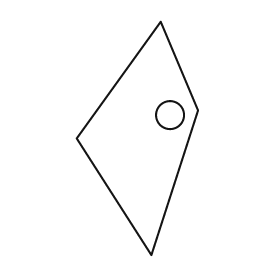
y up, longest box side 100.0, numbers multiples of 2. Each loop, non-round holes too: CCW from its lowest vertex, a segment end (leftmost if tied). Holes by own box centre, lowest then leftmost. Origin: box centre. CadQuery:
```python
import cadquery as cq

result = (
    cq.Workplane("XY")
    .moveTo(6.0, -50.0)
    .lineTo(26.0, 12.0)
    .lineTo(10.0, 50.0)
    .lineTo(-26.0, 0.0)
    .close()
    .moveTo(14.0, 10.0)
    .circle(6.0)
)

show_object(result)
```